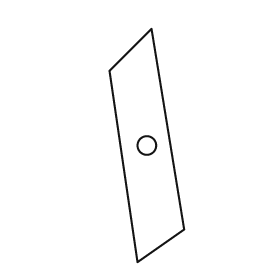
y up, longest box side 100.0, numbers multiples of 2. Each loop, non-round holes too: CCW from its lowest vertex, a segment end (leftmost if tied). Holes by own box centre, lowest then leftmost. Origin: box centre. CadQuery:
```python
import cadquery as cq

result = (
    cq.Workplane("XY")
    .moveTo(-4.0, -50.0)
    .lineTo(16.0, -36.0)
    .lineTo(2.0, 50.0)
    .lineTo(-16.0, 32.0)
    .close()
    .moveTo(0.0, 0.0)
    .circle(4.0)
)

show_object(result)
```